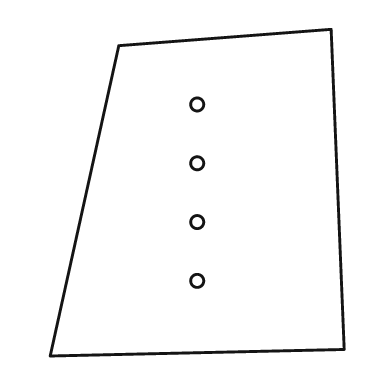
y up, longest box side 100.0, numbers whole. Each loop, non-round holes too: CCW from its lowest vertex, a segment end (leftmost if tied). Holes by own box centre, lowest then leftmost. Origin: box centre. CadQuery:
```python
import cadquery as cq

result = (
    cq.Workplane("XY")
    .moveTo(-45.0, -50.0)
    .lineTo(45.0, -48.0)
    .lineTo(41.0, 50.0)
    .lineTo(-24.0, 45.0)
    .close()
    .moveTo(0.0, -27.0)
    .circle(2.0)
    .moveTo(0.0, -9.0)
    .circle(2.0)
    .moveTo(0.0, 9.0)
    .circle(2.0)
    .moveTo(0.0, 27.0)
    .circle(2.0)
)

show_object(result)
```